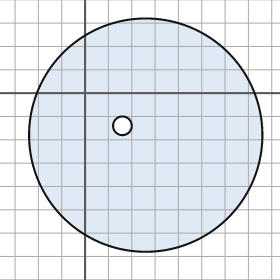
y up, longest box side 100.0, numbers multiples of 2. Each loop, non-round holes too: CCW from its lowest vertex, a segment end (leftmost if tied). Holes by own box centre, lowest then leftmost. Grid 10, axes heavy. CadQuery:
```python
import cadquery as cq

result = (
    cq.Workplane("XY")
    .moveTo(26.0, -18.0)
    .circle(50.0)
    .moveTo(16.0, -14.0)
    .circle(4.0)
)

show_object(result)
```